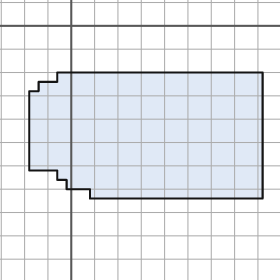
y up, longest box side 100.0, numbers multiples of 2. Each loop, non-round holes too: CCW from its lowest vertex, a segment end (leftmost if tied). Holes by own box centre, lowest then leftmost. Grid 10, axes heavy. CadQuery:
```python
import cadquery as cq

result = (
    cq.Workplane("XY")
    .moveTo(8.0, -74.0)
    .lineTo(82.0, -74.0)
    .lineTo(82.0, -20.0)
    .lineTo(-6.0, -20.0)
    .lineTo(-6.0, -24.0)
    .lineTo(-14.0, -24.0)
    .lineTo(-14.0, -28.0)
    .lineTo(-18.0, -28.0)
    .lineTo(-18.0, -62.0)
    .lineTo(-6.0, -62.0)
    .lineTo(-6.0, -66.0)
    .lineTo(-2.0, -66.0)
    .lineTo(-2.0, -70.0)
    .lineTo(8.0, -70.0)
    .close()
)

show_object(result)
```